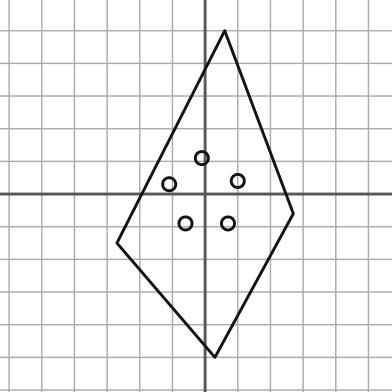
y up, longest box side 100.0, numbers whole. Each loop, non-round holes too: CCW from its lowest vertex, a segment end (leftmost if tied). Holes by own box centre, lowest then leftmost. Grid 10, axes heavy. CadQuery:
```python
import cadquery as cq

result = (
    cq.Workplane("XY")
    .moveTo(3.0, -50.0)
    .lineTo(27.0, -6.0)
    .lineTo(6.0, 50.0)
    .lineTo(-27.0, -15.0)
    .close()
    .moveTo(-6.0, -9.0)
    .circle(2.0)
    .moveTo(7.0, -9.0)
    .circle(2.0)
    .moveTo(-11.0, 3.0)
    .circle(2.0)
    .moveTo(10.0, 4.0)
    .circle(2.0)
    .moveTo(-1.0, 11.0)
    .circle(2.0)
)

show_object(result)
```